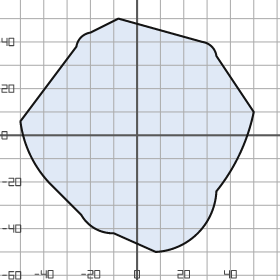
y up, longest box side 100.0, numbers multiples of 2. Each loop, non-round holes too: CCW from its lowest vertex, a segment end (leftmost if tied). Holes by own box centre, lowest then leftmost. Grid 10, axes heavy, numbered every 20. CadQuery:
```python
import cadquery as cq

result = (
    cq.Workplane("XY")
    .moveTo(8.0, -50.0)
    .threePointArc((26.0, -42.0), (34.0, -24.0))
    .threePointArc((44.0, -8.0), (50.0, 10.0))
    .lineTo(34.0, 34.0)
    .threePointArc((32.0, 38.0), (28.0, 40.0))
    .lineTo(-8.0, 50.0)
    .lineTo(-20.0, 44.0)
    .threePointArc((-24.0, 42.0), (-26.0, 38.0))
    .lineTo(-50.0, 6.0)
    .threePointArc((-46.0, -8.0), (-38.0, -20.0))
    .lineTo(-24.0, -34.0)
    .threePointArc((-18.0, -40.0), (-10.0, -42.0))
    .close()
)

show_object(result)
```